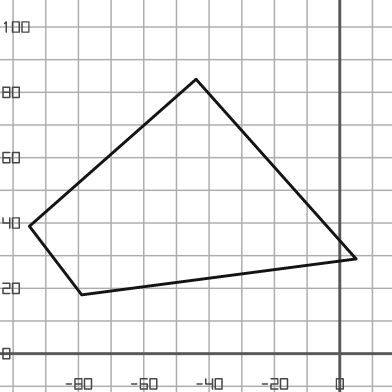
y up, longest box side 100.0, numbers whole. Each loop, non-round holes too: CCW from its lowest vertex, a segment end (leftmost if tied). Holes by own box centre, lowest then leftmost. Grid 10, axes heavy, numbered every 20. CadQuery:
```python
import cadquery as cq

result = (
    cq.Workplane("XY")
    .moveTo(-79.0, 18.0)
    .lineTo(5.0, 29.0)
    .lineTo(-44.0, 84.0)
    .lineTo(-95.0, 39.0)
    .close()
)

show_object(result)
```